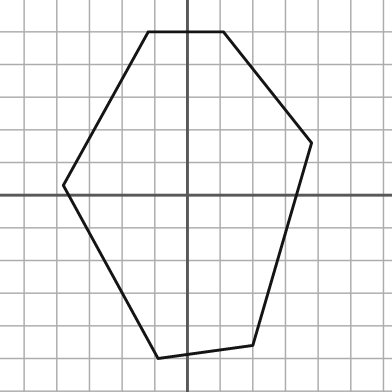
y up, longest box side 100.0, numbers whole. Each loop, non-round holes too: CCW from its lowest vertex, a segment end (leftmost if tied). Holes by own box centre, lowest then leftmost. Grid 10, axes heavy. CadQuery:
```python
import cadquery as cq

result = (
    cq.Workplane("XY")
    .moveTo(-9.0, -50.0)
    .lineTo(20.0, -46.0)
    .lineTo(38.0, 16.0)
    .lineTo(11.0, 50.0)
    .lineTo(-12.0, 50.0)
    .lineTo(-38.0, 3.0)
    .close()
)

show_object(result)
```